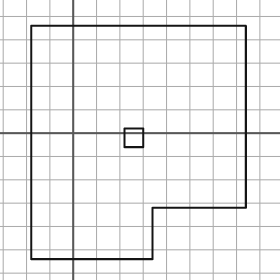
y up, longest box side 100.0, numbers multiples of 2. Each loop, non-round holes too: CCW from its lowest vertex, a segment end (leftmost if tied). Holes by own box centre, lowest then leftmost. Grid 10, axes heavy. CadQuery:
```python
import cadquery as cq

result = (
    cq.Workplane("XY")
    .moveTo(-18.0, -54.0)
    .lineTo(34.0, -54.0)
    .lineTo(34.0, -32.0)
    .lineTo(74.0, -32.0)
    .lineTo(74.0, 46.0)
    .lineTo(-18.0, 46.0)
    .close()
    .moveTo(22.0, -6.0)
    .lineTo(30.0, -6.0)
    .lineTo(30.0, 2.0)
    .lineTo(22.0, 2.0)
    .close()
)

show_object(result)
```